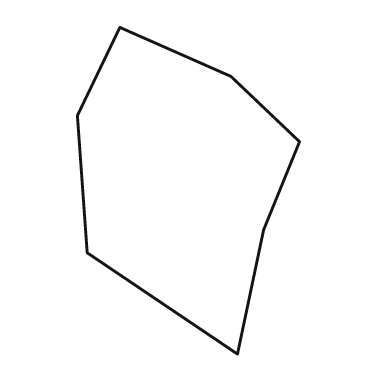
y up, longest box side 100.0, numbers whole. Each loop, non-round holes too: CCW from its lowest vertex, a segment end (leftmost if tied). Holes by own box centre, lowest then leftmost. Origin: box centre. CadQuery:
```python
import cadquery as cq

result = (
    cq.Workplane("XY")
    .moveTo(15.0, -50.0)
    .lineTo(23.0, -12.0)
    .lineTo(34.0, 15.0)
    .lineTo(13.0, 35.0)
    .lineTo(-21.0, 50.0)
    .lineTo(-34.0, 23.0)
    .lineTo(-31.0, -19.0)
    .close()
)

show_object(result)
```